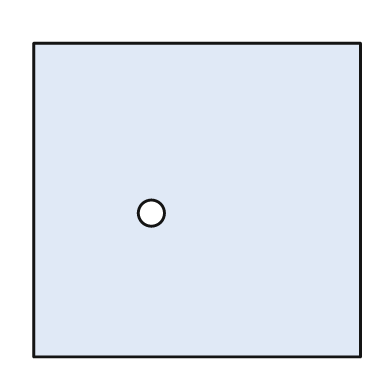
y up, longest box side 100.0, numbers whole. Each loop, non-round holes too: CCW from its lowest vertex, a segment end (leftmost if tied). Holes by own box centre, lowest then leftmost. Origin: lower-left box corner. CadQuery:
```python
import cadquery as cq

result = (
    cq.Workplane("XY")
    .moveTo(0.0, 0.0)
    .lineTo(100.0, 0.0)
    .lineTo(100.0, 96.0)
    .lineTo(0.0, 96.0)
    .close()
    .moveTo(36.0, 44.0)
    .circle(4.0)
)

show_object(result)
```